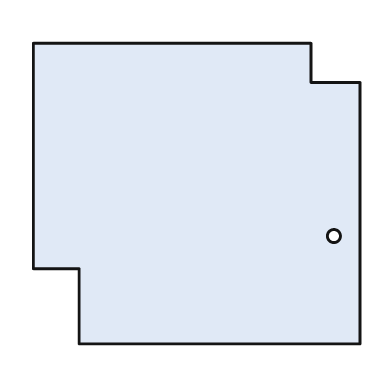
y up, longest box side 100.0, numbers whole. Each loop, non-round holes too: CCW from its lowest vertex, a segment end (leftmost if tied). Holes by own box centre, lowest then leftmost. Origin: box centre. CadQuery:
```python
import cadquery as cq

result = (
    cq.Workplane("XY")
    .moveTo(-36.0, -46.0)
    .lineTo(50.0, -46.0)
    .lineTo(50.0, 34.0)
    .lineTo(35.0, 34.0)
    .lineTo(35.0, 46.0)
    .lineTo(-50.0, 46.0)
    .lineTo(-50.0, -23.0)
    .lineTo(-36.0, -23.0)
    .close()
    .moveTo(42.0, -13.0)
    .circle(2.0)
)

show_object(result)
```